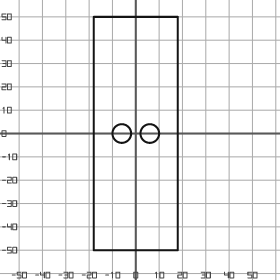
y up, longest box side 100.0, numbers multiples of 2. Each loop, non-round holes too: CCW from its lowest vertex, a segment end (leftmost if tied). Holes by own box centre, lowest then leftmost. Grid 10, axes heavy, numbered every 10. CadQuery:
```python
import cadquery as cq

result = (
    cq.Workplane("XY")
    .moveTo(-18.0, -50.0)
    .lineTo(18.0, -50.0)
    .lineTo(18.0, 50.0)
    .lineTo(-18.0, 50.0)
    .close()
    .moveTo(-6.0, 0.0)
    .circle(4.0)
    .moveTo(6.0, 0.0)
    .circle(4.0)
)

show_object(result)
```